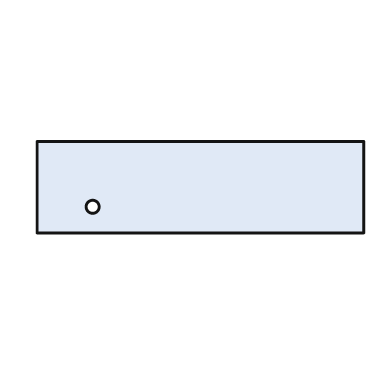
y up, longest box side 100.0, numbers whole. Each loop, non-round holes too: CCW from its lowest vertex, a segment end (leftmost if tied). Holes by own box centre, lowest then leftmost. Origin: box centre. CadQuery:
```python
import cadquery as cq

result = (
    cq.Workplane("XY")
    .moveTo(-50.0, -14.0)
    .lineTo(50.0, -14.0)
    .lineTo(50.0, 14.0)
    .lineTo(-50.0, 14.0)
    .close()
    .moveTo(-33.0, -6.0)
    .circle(2.0)
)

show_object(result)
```